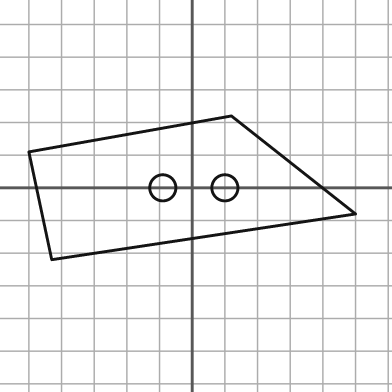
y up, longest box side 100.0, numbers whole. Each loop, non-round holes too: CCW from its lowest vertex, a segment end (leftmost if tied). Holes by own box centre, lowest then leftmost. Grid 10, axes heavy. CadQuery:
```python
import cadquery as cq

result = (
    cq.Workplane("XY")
    .moveTo(-43.0, -22.0)
    .lineTo(50.0, -8.0)
    .lineTo(12.0, 22.0)
    .lineTo(-50.0, 11.0)
    .close()
    .moveTo(-9.0, 0.0)
    .circle(4.0)
    .moveTo(10.0, 0.0)
    .circle(4.0)
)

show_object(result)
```